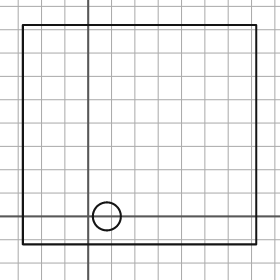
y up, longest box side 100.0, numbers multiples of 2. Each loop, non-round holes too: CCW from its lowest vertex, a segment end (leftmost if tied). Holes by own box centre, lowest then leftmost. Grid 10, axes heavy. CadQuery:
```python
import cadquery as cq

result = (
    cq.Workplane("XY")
    .moveTo(-28.0, -12.0)
    .lineTo(72.0, -12.0)
    .lineTo(72.0, 82.0)
    .lineTo(-28.0, 82.0)
    .close()
    .moveTo(8.0, 0.0)
    .circle(6.0)
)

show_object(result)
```